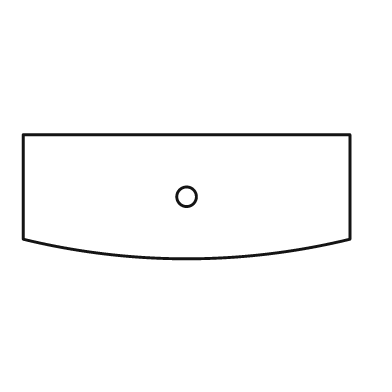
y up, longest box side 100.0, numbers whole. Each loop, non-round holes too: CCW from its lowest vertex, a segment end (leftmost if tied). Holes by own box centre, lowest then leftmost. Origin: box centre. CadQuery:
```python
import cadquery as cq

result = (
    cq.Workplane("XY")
    .moveTo(-50.0, -13.0)
    .threePointArc((0.0, -19.0), (50.0, -13.0))
    .lineTo(50.0, 19.0)
    .lineTo(-50.0, 19.0)
    .close()
    .moveTo(0.0, 0.0)
    .circle(3.0)
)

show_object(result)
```